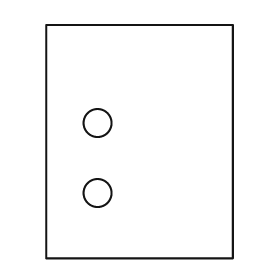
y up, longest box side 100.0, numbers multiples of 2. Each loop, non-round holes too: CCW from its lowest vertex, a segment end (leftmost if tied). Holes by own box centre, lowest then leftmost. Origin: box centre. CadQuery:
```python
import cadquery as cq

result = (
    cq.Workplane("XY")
    .moveTo(-40.0, -50.0)
    .lineTo(40.0, -50.0)
    .lineTo(40.0, 50.0)
    .lineTo(-40.0, 50.0)
    .close()
    .moveTo(-18.0, -22.0)
    .circle(6.0)
    .moveTo(-18.0, 8.0)
    .circle(6.0)
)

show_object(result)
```